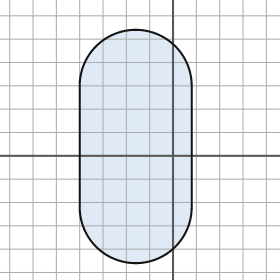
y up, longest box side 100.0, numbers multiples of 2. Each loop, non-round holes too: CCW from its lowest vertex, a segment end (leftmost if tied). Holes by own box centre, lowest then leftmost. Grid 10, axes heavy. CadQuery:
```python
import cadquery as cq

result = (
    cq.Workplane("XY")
    .moveTo(-40.0, -22.0)
    .threePointArc((-16.0, -46.0), (8.0, -22.0))
    .lineTo(8.0, 30.0)
    .threePointArc((-16.0, 54.0), (-40.0, 30.0))
    .close()
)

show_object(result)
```